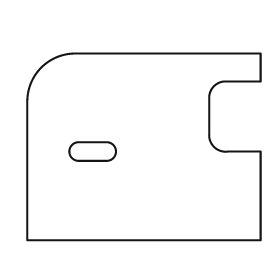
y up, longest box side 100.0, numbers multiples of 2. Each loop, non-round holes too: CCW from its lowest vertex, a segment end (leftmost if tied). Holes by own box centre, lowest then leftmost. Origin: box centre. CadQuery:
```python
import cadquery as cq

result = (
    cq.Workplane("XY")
    .moveTo(-50.0, -40.0)
    .lineTo(50.0, -40.0)
    .lineTo(50.0, -2.0)
    .lineTo(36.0, -2.0)
    .threePointArc((30.0, 0.0), (28.0, 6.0))
    .lineTo(28.0, 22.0)
    .threePointArc((30.0, 26.0), (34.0, 28.0))
    .lineTo(50.0, 28.0)
    .lineTo(50.0, 40.0)
    .lineTo(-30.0, 40.0)
    .threePointArc((-44.0, 34.0), (-50.0, 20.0))
    .close()
    .moveTo(-28.0, -6.0)
    .lineTo(-16.0, -6.0)
    .threePointArc((-12.0, -2.0), (-16.0, 2.0))
    .lineTo(-28.0, 2.0)
    .threePointArc((-32.0, -2.0), (-28.0, -6.0))
    .close()
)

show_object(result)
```